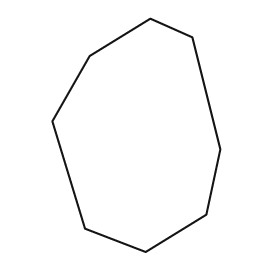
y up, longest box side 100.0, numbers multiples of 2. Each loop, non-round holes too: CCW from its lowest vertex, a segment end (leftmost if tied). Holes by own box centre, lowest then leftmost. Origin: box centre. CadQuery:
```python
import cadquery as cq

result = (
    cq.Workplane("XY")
    .moveTo(4.0, -50.0)
    .lineTo(30.0, -34.0)
    .lineTo(36.0, -6.0)
    .lineTo(24.0, 42.0)
    .lineTo(6.0, 50.0)
    .lineTo(-20.0, 34.0)
    .lineTo(-36.0, 6.0)
    .lineTo(-22.0, -40.0)
    .close()
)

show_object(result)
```